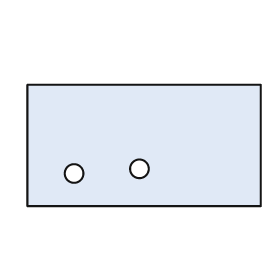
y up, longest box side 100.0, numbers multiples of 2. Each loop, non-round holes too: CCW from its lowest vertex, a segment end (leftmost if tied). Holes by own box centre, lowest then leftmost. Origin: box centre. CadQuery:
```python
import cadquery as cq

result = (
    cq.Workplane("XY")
    .moveTo(-50.0, -26.0)
    .lineTo(50.0, -26.0)
    .lineTo(50.0, 26.0)
    .lineTo(-50.0, 26.0)
    .close()
    .moveTo(-30.0, -12.0)
    .circle(4.0)
    .moveTo(-2.0, -10.0)
    .circle(4.0)
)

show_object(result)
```